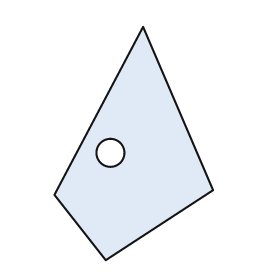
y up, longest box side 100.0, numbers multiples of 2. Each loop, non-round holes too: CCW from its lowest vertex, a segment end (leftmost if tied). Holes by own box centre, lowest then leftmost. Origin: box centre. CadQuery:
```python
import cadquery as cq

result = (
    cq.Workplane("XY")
    .moveTo(-12.0, -50.0)
    .lineTo(34.0, -20.0)
    .lineTo(4.0, 50.0)
    .lineTo(-34.0, -22.0)
    .close()
    .moveTo(-10.0, -4.0)
    .circle(6.0)
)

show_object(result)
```